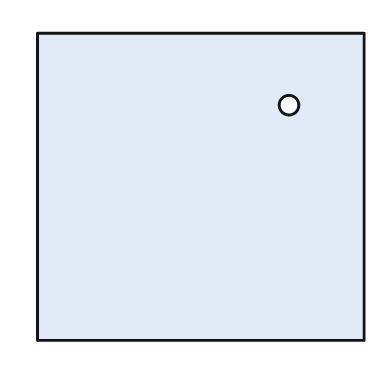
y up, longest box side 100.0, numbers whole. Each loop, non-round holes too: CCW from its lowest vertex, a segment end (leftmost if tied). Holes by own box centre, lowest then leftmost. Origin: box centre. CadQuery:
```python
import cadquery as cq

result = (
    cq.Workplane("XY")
    .moveTo(-50.0, -47.0)
    .lineTo(50.0, -47.0)
    .lineTo(50.0, 47.0)
    .lineTo(-50.0, 47.0)
    .close()
    .moveTo(27.0, 25.0)
    .circle(3.0)
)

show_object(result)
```